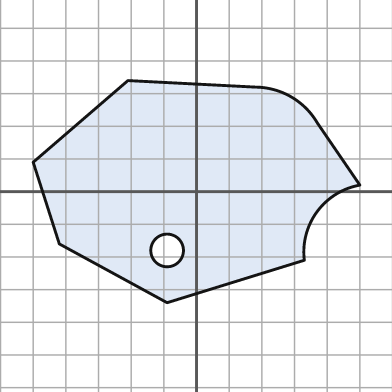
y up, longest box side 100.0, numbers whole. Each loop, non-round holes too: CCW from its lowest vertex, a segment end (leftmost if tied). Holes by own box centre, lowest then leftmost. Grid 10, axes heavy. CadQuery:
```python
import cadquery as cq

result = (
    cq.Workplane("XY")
    .moveTo(-9.0, -34.0)
    .lineTo(33.0, -21.0)
    .threePointArc((37.0, -6.0), (50.0, 2.0))
    .lineTo(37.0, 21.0)
    .threePointArc((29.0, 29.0), (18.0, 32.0))
    .lineTo(-21.0, 34.0)
    .lineTo(-50.0, 9.0)
    .lineTo(-42.0, -16.0)
    .close()
    .moveTo(-9.0, -18.0)
    .circle(5.0)
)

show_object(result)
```